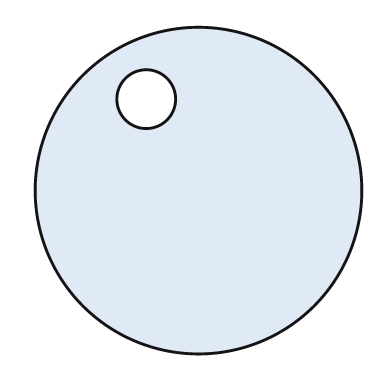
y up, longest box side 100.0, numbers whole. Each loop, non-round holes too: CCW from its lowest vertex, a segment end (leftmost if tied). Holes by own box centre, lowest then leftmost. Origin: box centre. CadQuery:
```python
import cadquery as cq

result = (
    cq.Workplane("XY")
    .moveTo(0.0, 0.0)
    .circle(50.0)
    .moveTo(-16.0, 28.0)
    .circle(9.0)
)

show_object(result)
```